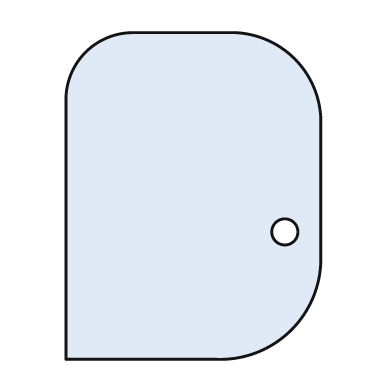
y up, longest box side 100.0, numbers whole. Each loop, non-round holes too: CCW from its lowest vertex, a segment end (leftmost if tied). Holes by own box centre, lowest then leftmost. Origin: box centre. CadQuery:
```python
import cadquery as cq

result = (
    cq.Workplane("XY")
    .moveTo(-39.0, -50.0)
    .lineTo(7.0, -50.0)
    .threePointArc((30.0, -41.0), (39.0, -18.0))
    .lineTo(39.0, 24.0)
    .threePointArc((31.0, 42.0), (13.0, 50.0))
    .lineTo(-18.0, 50.0)
    .threePointArc((-33.0, 44.0), (-39.0, 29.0))
    .close()
    .moveTo(28.0, -11.0)
    .circle(4.0)
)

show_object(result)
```